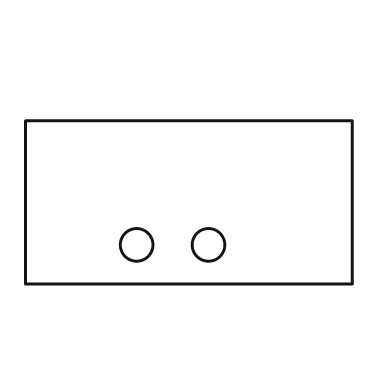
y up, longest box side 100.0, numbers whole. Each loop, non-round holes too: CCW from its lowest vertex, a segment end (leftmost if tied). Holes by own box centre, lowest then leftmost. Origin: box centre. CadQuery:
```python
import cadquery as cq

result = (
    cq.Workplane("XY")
    .moveTo(-50.0, -25.0)
    .lineTo(50.0, -25.0)
    .lineTo(50.0, 25.0)
    .lineTo(-50.0, 25.0)
    .close()
    .moveTo(-16.0, -13.0)
    .circle(5.0)
    .moveTo(6.0, -13.0)
    .circle(5.0)
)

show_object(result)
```